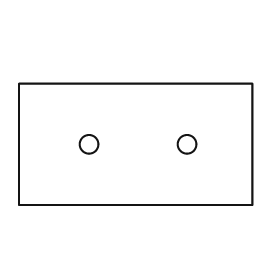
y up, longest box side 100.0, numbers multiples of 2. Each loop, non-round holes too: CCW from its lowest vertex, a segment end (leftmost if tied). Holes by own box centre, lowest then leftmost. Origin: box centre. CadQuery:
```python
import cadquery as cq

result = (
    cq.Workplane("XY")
    .moveTo(-50.0, -26.0)
    .lineTo(50.0, -26.0)
    .lineTo(50.0, 26.0)
    .lineTo(-50.0, 26.0)
    .close()
    .moveTo(-20.0, 0.0)
    .circle(4.0)
    .moveTo(22.0, 0.0)
    .circle(4.0)
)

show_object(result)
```